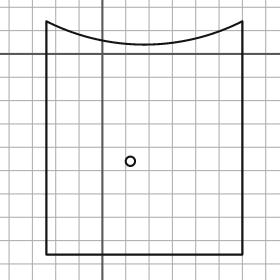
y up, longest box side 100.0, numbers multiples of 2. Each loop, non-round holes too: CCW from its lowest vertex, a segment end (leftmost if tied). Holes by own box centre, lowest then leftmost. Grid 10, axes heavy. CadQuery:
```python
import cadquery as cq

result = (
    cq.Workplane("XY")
    .moveTo(-24.0, -86.0)
    .lineTo(60.0, -86.0)
    .lineTo(60.0, 14.0)
    .threePointArc((18.0, 4.0), (-24.0, 14.0))
    .close()
    .moveTo(12.0, -46.0)
    .circle(2.0)
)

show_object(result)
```